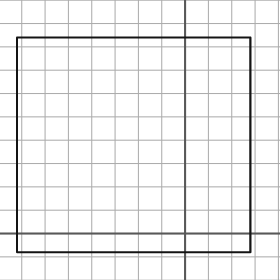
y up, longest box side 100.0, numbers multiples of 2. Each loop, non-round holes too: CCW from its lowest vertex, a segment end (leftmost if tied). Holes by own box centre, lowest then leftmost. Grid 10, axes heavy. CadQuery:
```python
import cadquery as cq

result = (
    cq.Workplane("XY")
    .moveTo(-72.0, -8.0)
    .lineTo(28.0, -8.0)
    .lineTo(28.0, 84.0)
    .lineTo(-72.0, 84.0)
    .close()
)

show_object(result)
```